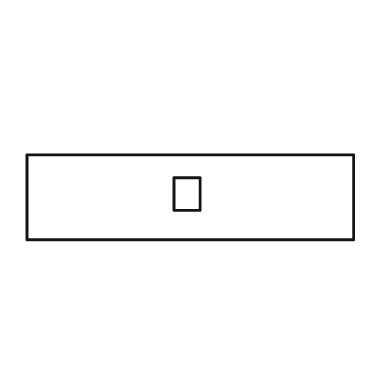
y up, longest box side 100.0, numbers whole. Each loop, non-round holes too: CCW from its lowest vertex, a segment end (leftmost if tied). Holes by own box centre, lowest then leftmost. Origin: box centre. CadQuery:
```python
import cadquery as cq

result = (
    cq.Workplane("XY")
    .moveTo(-50.0, -13.0)
    .lineTo(50.0, -13.0)
    .lineTo(50.0, 13.0)
    .lineTo(-50.0, 13.0)
    .close()
    .moveTo(-5.0, -4.0)
    .lineTo(3.0, -4.0)
    .lineTo(3.0, 6.0)
    .lineTo(-5.0, 6.0)
    .close()
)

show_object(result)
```